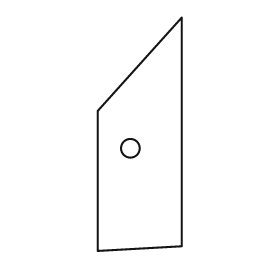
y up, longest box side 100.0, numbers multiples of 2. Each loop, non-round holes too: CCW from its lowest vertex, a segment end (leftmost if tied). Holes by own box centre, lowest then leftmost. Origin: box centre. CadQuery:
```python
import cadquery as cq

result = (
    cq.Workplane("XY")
    .moveTo(-18.0, -50.0)
    .lineTo(18.0, -48.0)
    .lineTo(18.0, 50.0)
    .lineTo(-18.0, 10.0)
    .close()
    .moveTo(-4.0, -6.0)
    .circle(4.0)
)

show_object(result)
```